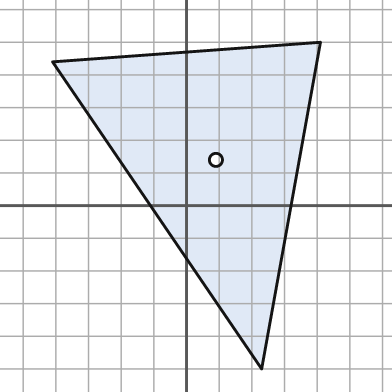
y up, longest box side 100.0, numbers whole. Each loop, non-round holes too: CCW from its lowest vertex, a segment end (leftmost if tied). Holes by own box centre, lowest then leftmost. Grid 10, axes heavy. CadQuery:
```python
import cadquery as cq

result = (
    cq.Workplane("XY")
    .moveTo(23.0, -50.0)
    .lineTo(41.0, 50.0)
    .lineTo(-41.0, 44.0)
    .close()
    .moveTo(9.0, 14.0)
    .circle(2.0)
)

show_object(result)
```